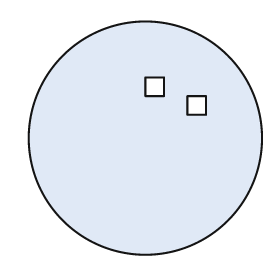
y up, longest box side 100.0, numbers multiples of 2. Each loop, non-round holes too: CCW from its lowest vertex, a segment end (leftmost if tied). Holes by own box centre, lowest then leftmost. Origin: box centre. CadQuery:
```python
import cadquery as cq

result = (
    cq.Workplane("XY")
    .moveTo(0.0, 0.0)
    .circle(50.0)
    .moveTo(18.0, 10.0)
    .lineTo(26.0, 10.0)
    .lineTo(26.0, 18.0)
    .lineTo(18.0, 18.0)
    .close()
    .moveTo(0.0, 18.0)
    .lineTo(8.0, 18.0)
    .lineTo(8.0, 26.0)
    .lineTo(0.0, 26.0)
    .close()
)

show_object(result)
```